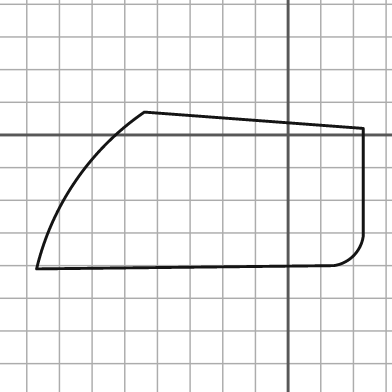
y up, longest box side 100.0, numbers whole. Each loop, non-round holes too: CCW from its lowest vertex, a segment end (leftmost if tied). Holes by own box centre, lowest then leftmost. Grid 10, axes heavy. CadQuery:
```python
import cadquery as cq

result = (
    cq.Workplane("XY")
    .moveTo(-77.0, -41.0)
    .lineTo(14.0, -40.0)
    .threePointArc((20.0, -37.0), (23.0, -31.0))
    .lineTo(23.0, 2.0)
    .lineTo(-44.0, 7.0)
    .threePointArc((-65.0, -14.0), (-77.0, -41.0))
    .close()
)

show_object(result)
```